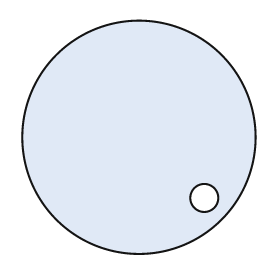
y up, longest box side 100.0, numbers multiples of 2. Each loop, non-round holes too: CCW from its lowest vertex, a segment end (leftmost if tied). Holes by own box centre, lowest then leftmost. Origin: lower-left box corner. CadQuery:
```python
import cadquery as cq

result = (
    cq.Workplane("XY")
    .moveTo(50.0, 50.0)
    .circle(50.0)
    .moveTo(78.0, 24.0)
    .circle(6.0)
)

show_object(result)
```